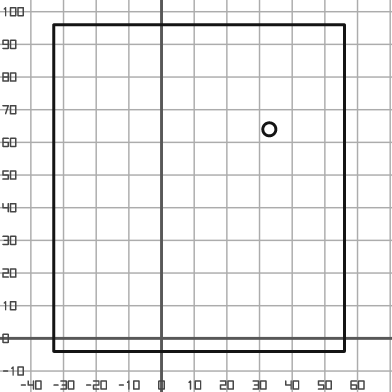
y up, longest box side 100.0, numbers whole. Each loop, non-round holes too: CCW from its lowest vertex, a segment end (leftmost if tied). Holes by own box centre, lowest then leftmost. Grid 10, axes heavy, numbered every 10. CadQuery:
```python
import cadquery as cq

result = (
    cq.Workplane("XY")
    .moveTo(-33.0, -4.0)
    .lineTo(56.0, -4.0)
    .lineTo(56.0, 96.0)
    .lineTo(-33.0, 96.0)
    .close()
    .moveTo(33.0, 64.0)
    .circle(2.0)
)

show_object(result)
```